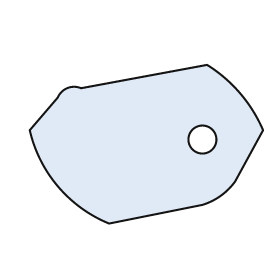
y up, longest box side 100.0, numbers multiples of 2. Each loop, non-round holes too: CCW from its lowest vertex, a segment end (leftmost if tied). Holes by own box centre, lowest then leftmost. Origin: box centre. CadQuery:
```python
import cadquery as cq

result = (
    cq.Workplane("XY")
    .moveTo(-16.0, -34.0)
    .lineTo(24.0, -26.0)
    .threePointArc((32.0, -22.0), (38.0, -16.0))
    .lineTo(50.0, 6.0)
    .threePointArc((40.0, 22.0), (26.0, 34.0))
    .lineTo(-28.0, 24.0)
    .threePointArc((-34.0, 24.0), (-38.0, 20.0))
    .lineTo(-50.0, 6.0)
    .threePointArc((-38.0, -18.0), (-16.0, -34.0))
    .close()
    .moveTo(24.0, 2.0)
    .circle(6.0)
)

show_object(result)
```